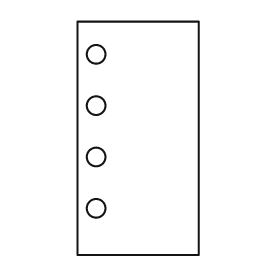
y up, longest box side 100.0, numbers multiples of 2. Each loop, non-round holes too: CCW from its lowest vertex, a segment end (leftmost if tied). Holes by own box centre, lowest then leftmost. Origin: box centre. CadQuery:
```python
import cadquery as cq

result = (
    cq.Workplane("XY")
    .moveTo(-26.0, -50.0)
    .lineTo(26.0, -50.0)
    .lineTo(26.0, 50.0)
    .lineTo(-26.0, 50.0)
    .close()
    .moveTo(-18.0, -30.0)
    .circle(4.0)
    .moveTo(-18.0, -8.0)
    .circle(4.0)
    .moveTo(-18.0, 14.0)
    .circle(4.0)
    .moveTo(-18.0, 36.0)
    .circle(4.0)
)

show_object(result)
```